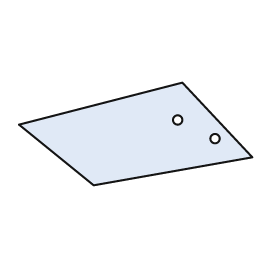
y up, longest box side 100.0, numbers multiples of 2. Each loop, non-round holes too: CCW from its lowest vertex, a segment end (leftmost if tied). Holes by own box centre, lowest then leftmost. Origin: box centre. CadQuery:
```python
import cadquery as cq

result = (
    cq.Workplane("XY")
    .moveTo(-18.0, -22.0)
    .lineTo(50.0, -10.0)
    .lineTo(20.0, 22.0)
    .lineTo(-50.0, 4.0)
    .close()
    .moveTo(34.0, -2.0)
    .circle(2.0)
    .moveTo(18.0, 6.0)
    .circle(2.0)
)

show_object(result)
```